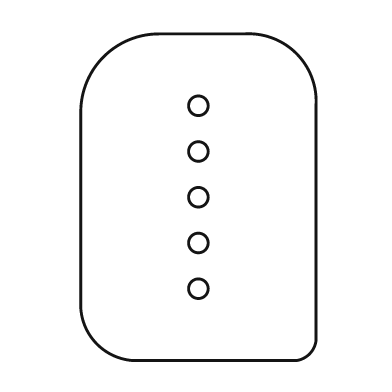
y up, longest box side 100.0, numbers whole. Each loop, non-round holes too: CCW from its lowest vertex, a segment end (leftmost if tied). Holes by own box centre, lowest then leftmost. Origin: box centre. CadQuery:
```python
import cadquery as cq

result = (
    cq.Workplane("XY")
    .moveTo(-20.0, -50.0)
    .lineTo(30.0, -50.0)
    .threePointArc((34.0, -48.0), (36.0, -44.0))
    .lineTo(36.0, 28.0)
    .threePointArc((30.0, 44.0), (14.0, 50.0))
    .lineTo(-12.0, 50.0)
    .threePointArc((-29.0, 43.0), (-36.0, 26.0))
    .lineTo(-36.0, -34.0)
    .threePointArc((-31.0, -45.0), (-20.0, -50.0))
    .close()
    .moveTo(0.0, -28.0)
    .circle(3.0)
    .moveTo(0.0, -14.0)
    .circle(3.0)
    .moveTo(0.0, 0.0)
    .circle(3.0)
    .moveTo(0.0, 14.0)
    .circle(3.0)
    .moveTo(0.0, 28.0)
    .circle(3.0)
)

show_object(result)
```